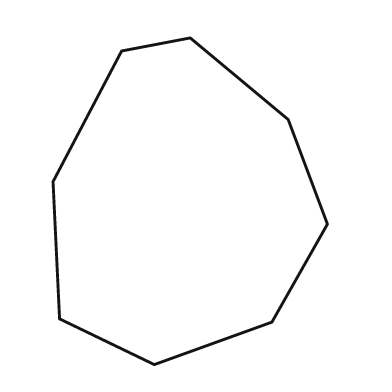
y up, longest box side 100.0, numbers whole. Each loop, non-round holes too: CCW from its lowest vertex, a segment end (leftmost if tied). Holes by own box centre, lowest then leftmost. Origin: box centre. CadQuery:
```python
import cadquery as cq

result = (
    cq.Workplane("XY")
    .moveTo(-11.0, -50.0)
    .lineTo(25.0, -37.0)
    .lineTo(42.0, -7.0)
    .lineTo(30.0, 25.0)
    .lineTo(0.0, 50.0)
    .lineTo(-21.0, 46.0)
    .lineTo(-42.0, 6.0)
    .lineTo(-40.0, -36.0)
    .close()
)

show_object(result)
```